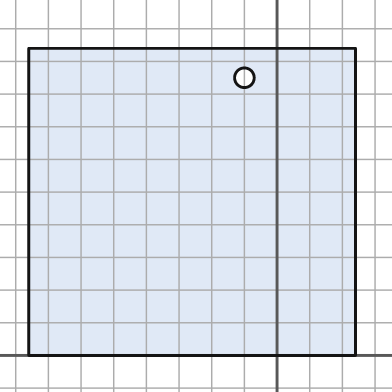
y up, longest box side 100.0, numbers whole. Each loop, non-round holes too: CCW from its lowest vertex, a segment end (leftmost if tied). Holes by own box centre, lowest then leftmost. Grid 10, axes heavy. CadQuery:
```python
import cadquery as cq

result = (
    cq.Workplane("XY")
    .moveTo(-76.0, 0.0)
    .lineTo(24.0, 0.0)
    .lineTo(24.0, 94.0)
    .lineTo(-76.0, 94.0)
    .close()
    .moveTo(-10.0, 85.0)
    .circle(3.0)
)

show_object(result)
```